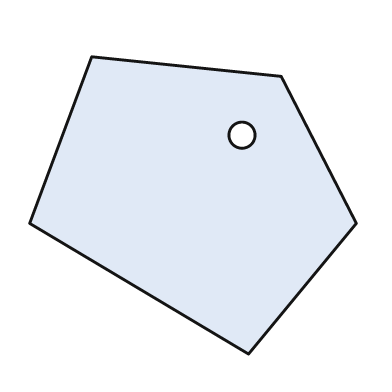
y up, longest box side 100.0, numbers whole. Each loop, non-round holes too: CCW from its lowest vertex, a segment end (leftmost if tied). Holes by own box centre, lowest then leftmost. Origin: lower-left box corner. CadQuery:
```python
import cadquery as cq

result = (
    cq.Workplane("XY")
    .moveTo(67.0, 0.0)
    .lineTo(100.0, 40.0)
    .lineTo(77.0, 85.0)
    .lineTo(19.0, 91.0)
    .lineTo(0.0, 40.0)
    .close()
    .moveTo(65.0, 67.0)
    .circle(4.0)
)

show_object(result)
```